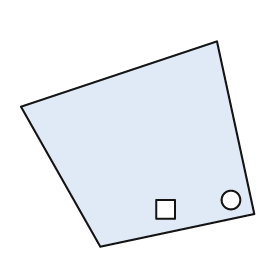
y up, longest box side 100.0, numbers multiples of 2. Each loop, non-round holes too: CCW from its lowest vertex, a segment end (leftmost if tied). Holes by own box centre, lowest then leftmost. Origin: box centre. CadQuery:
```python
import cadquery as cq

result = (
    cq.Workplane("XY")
    .moveTo(-16.0, -44.0)
    .lineTo(50.0, -30.0)
    .lineTo(34.0, 44.0)
    .lineTo(-50.0, 16.0)
    .close()
    .moveTo(8.0, -32.0)
    .lineTo(16.0, -32.0)
    .lineTo(16.0, -24.0)
    .lineTo(8.0, -24.0)
    .close()
    .moveTo(40.0, -24.0)
    .circle(4.0)
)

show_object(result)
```